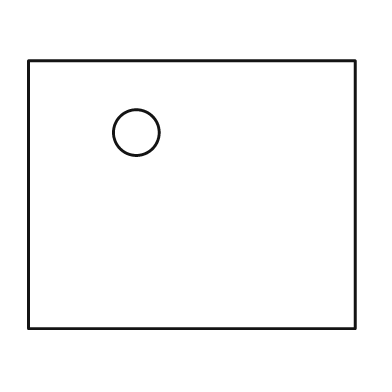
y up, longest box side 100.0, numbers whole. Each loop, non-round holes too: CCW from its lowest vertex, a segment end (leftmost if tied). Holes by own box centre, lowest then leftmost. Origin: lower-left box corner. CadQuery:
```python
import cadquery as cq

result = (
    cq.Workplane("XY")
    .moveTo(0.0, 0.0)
    .lineTo(100.0, 0.0)
    .lineTo(100.0, 82.0)
    .lineTo(0.0, 82.0)
    .close()
    .moveTo(33.0, 60.0)
    .circle(7.0)
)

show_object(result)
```